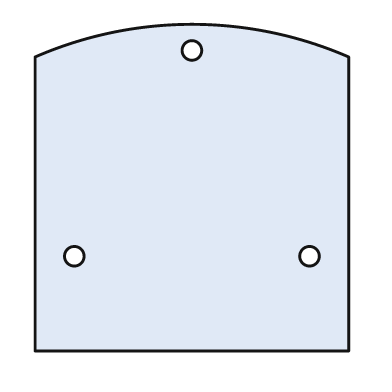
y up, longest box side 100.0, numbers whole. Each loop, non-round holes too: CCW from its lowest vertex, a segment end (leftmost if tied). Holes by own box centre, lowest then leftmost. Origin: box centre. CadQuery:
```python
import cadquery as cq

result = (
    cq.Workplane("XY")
    .moveTo(-48.0, -50.0)
    .lineTo(48.0, -50.0)
    .lineTo(48.0, 40.0)
    .threePointArc((0.0, 50.0), (-48.0, 40.0))
    .close()
    .moveTo(-36.0, -21.0)
    .circle(3.0)
    .moveTo(36.0, -21.0)
    .circle(3.0)
    .moveTo(0.0, 42.0)
    .circle(3.0)
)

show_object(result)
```